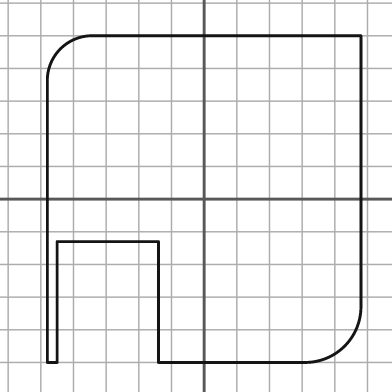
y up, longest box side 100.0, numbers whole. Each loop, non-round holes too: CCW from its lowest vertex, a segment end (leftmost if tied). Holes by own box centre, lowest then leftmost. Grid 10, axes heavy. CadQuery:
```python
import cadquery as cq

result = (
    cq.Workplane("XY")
    .moveTo(-48.0, -50.0)
    .lineTo(-45.0, -50.0)
    .lineTo(-45.0, -13.0)
    .lineTo(-14.0, -13.0)
    .lineTo(-14.0, -50.0)
    .lineTo(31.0, -50.0)
    .threePointArc((43.0, -45.0), (48.0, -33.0))
    .lineTo(48.0, 50.0)
    .lineTo(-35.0, 50.0)
    .threePointArc((-44.0, 46.0), (-48.0, 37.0))
    .close()
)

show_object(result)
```